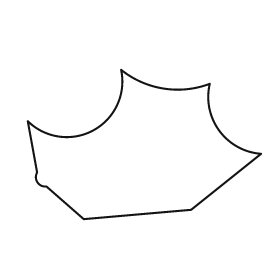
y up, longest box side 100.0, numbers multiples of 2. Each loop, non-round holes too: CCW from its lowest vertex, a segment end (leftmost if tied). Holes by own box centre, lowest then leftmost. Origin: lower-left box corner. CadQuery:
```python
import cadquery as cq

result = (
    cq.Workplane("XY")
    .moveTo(24.0, 0.0)
    .lineTo(70.0, 4.0)
    .lineTo(100.0, 28.0)
    .threePointArc((82.0, 38.0), (78.0, 58.0))
    .threePointArc((58.0, 56.0), (40.0, 64.0))
    .threePointArc((28.0, 38.0), (0.0, 42.0))
    .lineTo(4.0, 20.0)
    .threePointArc((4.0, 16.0), (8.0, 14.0))
    .close()
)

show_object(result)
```